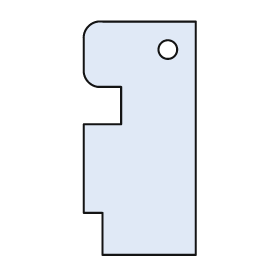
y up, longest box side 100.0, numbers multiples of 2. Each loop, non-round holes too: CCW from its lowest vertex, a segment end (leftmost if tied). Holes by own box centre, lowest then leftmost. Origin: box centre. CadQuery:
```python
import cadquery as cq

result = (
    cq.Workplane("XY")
    .moveTo(-16.0, -50.0)
    .lineTo(24.0, -50.0)
    .lineTo(24.0, 50.0)
    .lineTo(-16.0, 50.0)
    .threePointArc((-22.0, 48.0), (-24.0, 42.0))
    .lineTo(-24.0, 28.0)
    .threePointArc((-22.0, 24.0), (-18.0, 22.0))
    .lineTo(-8.0, 22.0)
    .lineTo(-8.0, 6.0)
    .lineTo(-24.0, 6.0)
    .lineTo(-24.0, -32.0)
    .lineTo(-16.0, -32.0)
    .close()
    .moveTo(12.0, 38.0)
    .circle(4.0)
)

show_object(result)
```